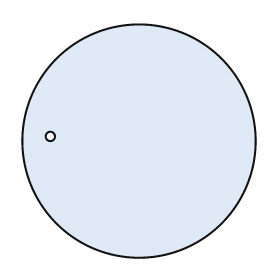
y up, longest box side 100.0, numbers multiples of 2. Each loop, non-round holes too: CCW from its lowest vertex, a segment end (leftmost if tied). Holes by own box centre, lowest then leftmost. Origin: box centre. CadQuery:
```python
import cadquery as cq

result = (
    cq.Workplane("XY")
    .moveTo(0.0, 0.0)
    .circle(50.0)
    .moveTo(-38.0, 2.0)
    .circle(2.0)
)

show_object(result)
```